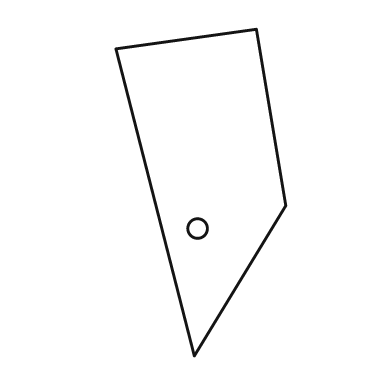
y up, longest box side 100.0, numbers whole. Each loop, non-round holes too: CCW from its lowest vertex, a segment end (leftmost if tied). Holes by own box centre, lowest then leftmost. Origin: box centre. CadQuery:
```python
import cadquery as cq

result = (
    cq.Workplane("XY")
    .moveTo(-2.0, -50.0)
    .lineTo(26.0, -4.0)
    .lineTo(17.0, 50.0)
    .lineTo(-26.0, 44.0)
    .close()
    .moveTo(-1.0, -11.0)
    .circle(3.0)
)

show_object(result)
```